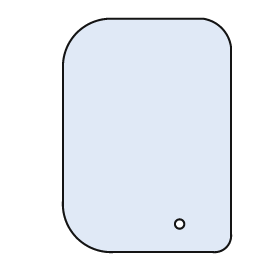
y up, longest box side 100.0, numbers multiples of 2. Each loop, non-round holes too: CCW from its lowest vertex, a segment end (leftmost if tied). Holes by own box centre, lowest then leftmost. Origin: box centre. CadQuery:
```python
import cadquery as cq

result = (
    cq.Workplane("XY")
    .moveTo(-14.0, -50.0)
    .lineTo(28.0, -50.0)
    .threePointArc((34.0, -48.0), (36.0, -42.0))
    .lineTo(36.0, 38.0)
    .threePointArc((32.0, 46.0), (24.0, 50.0))
    .lineTo(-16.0, 50.0)
    .threePointArc((-30.0, 44.0), (-36.0, 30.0))
    .lineTo(-36.0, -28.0)
    .threePointArc((-30.0, -44.0), (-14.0, -50.0))
    .close()
    .moveTo(14.0, -38.0)
    .circle(2.0)
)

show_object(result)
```